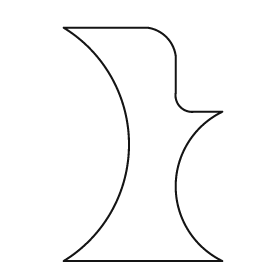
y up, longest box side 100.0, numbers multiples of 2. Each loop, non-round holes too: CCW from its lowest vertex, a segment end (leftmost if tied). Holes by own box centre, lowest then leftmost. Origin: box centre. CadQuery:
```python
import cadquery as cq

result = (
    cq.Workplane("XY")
    .moveTo(-34.0, -50.0)
    .lineTo(34.0, -50.0)
    .threePointArc((14.0, -18.0), (34.0, 14.0))
    .lineTo(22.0, 14.0)
    .threePointArc((16.0, 16.0), (14.0, 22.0))
    .lineTo(14.0, 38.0)
    .threePointArc((10.0, 46.0), (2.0, 50.0))
    .lineTo(-34.0, 50.0)
    .threePointArc((-6.0, 0.0), (-34.0, -50.0))
    .close()
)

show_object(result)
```